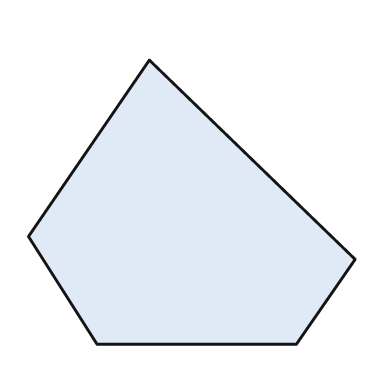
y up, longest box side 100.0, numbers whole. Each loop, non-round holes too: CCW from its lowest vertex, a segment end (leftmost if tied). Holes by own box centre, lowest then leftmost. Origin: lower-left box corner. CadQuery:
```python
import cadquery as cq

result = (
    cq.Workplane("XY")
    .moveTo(21.0, 0.0)
    .lineTo(82.0, 0.0)
    .lineTo(100.0, 26.0)
    .lineTo(37.0, 87.0)
    .lineTo(0.0, 33.0)
    .close()
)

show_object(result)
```